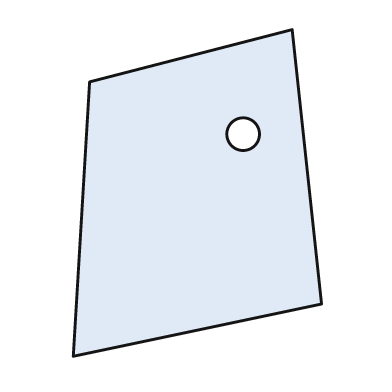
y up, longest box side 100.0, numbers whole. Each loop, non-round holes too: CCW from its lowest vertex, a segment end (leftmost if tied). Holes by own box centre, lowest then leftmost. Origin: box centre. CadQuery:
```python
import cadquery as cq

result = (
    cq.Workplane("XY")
    .moveTo(-38.0, -50.0)
    .lineTo(38.0, -34.0)
    .lineTo(29.0, 50.0)
    .lineTo(-33.0, 34.0)
    .close()
    .moveTo(14.0, 18.0)
    .circle(5.0)
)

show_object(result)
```